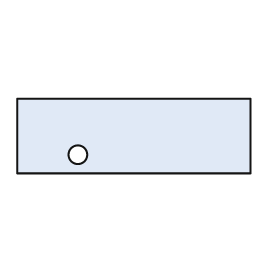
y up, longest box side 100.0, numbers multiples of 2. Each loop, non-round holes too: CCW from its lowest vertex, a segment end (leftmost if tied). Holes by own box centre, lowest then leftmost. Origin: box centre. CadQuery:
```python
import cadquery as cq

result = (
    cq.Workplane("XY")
    .moveTo(-50.0, -16.0)
    .lineTo(50.0, -16.0)
    .lineTo(50.0, 16.0)
    .lineTo(-50.0, 16.0)
    .close()
    .moveTo(-24.0, -8.0)
    .circle(4.0)
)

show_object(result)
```